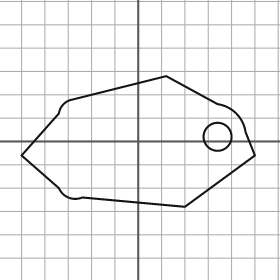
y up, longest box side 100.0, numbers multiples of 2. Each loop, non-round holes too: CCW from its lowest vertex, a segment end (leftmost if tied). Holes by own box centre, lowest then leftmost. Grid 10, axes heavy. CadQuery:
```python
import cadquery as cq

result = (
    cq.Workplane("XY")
    .moveTo(20.0, -28.0)
    .lineTo(50.0, -6.0)
    .lineTo(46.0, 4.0)
    .threePointArc((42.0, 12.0), (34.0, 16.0))
    .lineTo(12.0, 28.0)
    .lineTo(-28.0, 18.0)
    .threePointArc((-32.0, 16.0), (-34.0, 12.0))
    .lineTo(-50.0, -6.0)
    .lineTo(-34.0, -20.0)
    .threePointArc((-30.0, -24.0), (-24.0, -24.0))
    .close()
    .moveTo(34.0, 2.0)
    .circle(6.0)
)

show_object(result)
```